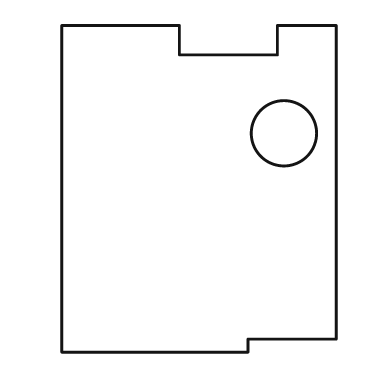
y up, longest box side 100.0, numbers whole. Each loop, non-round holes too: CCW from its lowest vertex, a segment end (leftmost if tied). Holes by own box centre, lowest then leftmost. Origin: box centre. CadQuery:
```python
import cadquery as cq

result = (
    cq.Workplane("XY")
    .moveTo(-42.0, -50.0)
    .lineTo(15.0, -50.0)
    .lineTo(15.0, -46.0)
    .lineTo(42.0, -46.0)
    .lineTo(42.0, 50.0)
    .lineTo(24.0, 50.0)
    .lineTo(24.0, 41.0)
    .lineTo(-6.0, 41.0)
    .lineTo(-6.0, 50.0)
    .lineTo(-42.0, 50.0)
    .close()
    .moveTo(26.0, 17.0)
    .circle(10.0)
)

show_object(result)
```